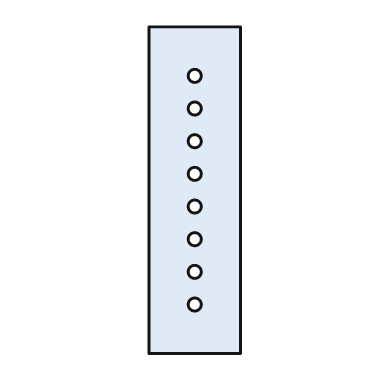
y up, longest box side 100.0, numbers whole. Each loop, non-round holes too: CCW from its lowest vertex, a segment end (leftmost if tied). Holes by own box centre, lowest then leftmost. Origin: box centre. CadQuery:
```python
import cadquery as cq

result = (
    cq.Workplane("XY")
    .moveTo(-14.0, -50.0)
    .lineTo(14.0, -50.0)
    .lineTo(14.0, 50.0)
    .lineTo(-14.0, 50.0)
    .close()
    .moveTo(0.0, -35.0)
    .circle(2.0)
    .moveTo(0.0, -25.0)
    .circle(2.0)
    .moveTo(0.0, -15.0)
    .circle(2.0)
    .moveTo(0.0, -5.0)
    .circle(2.0)
    .moveTo(0.0, 5.0)
    .circle(2.0)
    .moveTo(0.0, 15.0)
    .circle(2.0)
    .moveTo(0.0, 25.0)
    .circle(2.0)
    .moveTo(0.0, 35.0)
    .circle(2.0)
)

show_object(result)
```